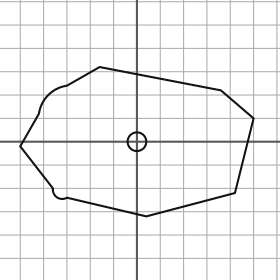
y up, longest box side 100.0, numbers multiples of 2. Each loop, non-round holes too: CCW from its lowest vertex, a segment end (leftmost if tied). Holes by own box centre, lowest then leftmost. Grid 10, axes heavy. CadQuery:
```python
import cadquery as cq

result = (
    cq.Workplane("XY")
    .moveTo(4.0, -32.0)
    .lineTo(42.0, -22.0)
    .lineTo(50.0, 10.0)
    .lineTo(36.0, 22.0)
    .lineTo(-16.0, 32.0)
    .lineTo(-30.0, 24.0)
    .threePointArc((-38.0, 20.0), (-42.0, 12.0))
    .lineTo(-50.0, -2.0)
    .lineTo(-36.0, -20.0)
    .threePointArc((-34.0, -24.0), (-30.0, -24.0))
    .close()
    .moveTo(0.0, 0.0)
    .circle(4.0)
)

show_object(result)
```